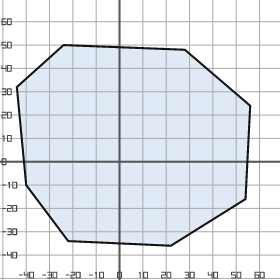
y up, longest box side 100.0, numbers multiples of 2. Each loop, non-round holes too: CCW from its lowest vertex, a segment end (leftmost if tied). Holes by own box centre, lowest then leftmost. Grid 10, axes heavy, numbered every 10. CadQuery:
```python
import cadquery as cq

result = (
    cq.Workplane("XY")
    .moveTo(22.0, -36.0)
    .lineTo(54.0, -16.0)
    .lineTo(56.0, 24.0)
    .lineTo(28.0, 48.0)
    .lineTo(-24.0, 50.0)
    .lineTo(-44.0, 32.0)
    .lineTo(-40.0, -10.0)
    .lineTo(-22.0, -34.0)
    .close()
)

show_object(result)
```